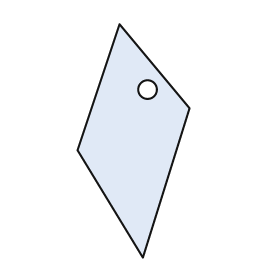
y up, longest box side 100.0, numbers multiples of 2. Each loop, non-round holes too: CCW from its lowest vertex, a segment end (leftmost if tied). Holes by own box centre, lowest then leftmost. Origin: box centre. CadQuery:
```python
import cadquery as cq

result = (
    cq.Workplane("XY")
    .moveTo(4.0, -50.0)
    .lineTo(24.0, 14.0)
    .lineTo(-6.0, 50.0)
    .lineTo(-24.0, -4.0)
    .close()
    .moveTo(6.0, 22.0)
    .circle(4.0)
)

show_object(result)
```